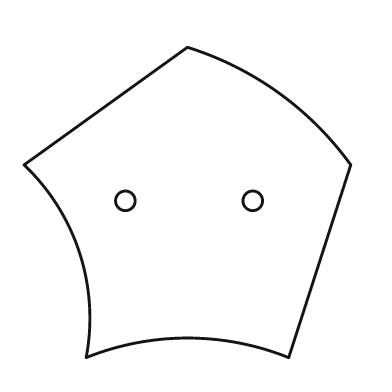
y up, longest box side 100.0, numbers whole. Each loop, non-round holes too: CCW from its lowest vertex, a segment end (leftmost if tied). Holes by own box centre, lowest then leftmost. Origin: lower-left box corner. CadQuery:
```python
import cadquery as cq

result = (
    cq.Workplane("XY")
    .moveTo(19.0, 0.0)
    .threePointArc((50.0, 6.0), (81.0, 0.0))
    .lineTo(100.0, 59.0)
    .threePointArc((78.0, 81.0), (50.0, 95.0))
    .lineTo(0.0, 59.0)
    .threePointArc((17.0, 32.0), (19.0, 0.0))
    .close()
    .moveTo(31.0, 48.0)
    .circle(3.0)
    .moveTo(70.0, 48.0)
    .circle(3.0)
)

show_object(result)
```